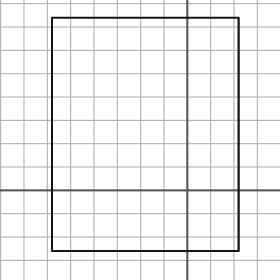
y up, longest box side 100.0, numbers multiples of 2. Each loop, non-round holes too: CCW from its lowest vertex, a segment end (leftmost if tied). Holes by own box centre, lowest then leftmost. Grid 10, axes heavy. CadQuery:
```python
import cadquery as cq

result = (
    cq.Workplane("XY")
    .moveTo(-58.0, -26.0)
    .lineTo(22.0, -26.0)
    .lineTo(22.0, 74.0)
    .lineTo(-58.0, 74.0)
    .close()
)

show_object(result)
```